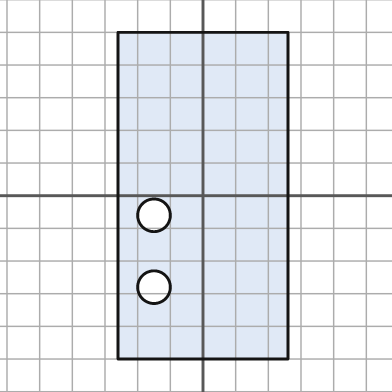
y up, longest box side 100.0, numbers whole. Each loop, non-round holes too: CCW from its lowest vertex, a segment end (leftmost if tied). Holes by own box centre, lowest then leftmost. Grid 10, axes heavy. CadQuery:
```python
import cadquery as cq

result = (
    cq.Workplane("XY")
    .moveTo(-26.0, -50.0)
    .lineTo(26.0, -50.0)
    .lineTo(26.0, 50.0)
    .lineTo(-26.0, 50.0)
    .close()
    .moveTo(-15.0, -28.0)
    .circle(5.0)
    .moveTo(-15.0, -6.0)
    .circle(5.0)
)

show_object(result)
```